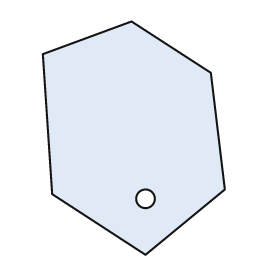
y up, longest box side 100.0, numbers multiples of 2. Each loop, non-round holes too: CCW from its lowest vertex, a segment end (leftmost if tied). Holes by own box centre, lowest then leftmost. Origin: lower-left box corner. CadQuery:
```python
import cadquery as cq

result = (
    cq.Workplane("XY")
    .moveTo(44.0, 0.0)
    .lineTo(78.0, 28.0)
    .lineTo(72.0, 78.0)
    .lineTo(38.0, 100.0)
    .lineTo(0.0, 86.0)
    .lineTo(4.0, 26.0)
    .close()
    .moveTo(44.0, 24.0)
    .circle(4.0)
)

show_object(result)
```